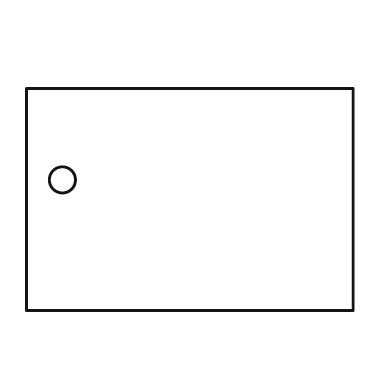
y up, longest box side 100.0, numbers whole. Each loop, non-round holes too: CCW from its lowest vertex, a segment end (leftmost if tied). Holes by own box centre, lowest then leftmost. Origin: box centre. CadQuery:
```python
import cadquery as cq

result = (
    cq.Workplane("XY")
    .moveTo(-50.0, -34.0)
    .lineTo(50.0, -34.0)
    .lineTo(50.0, 34.0)
    .lineTo(-50.0, 34.0)
    .close()
    .moveTo(-39.0, 6.0)
    .circle(4.0)
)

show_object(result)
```